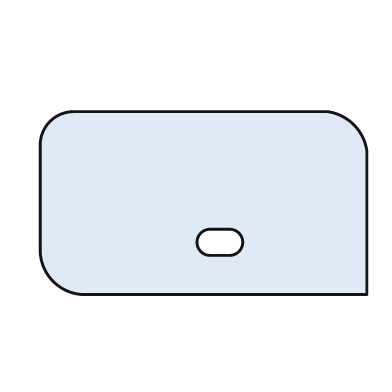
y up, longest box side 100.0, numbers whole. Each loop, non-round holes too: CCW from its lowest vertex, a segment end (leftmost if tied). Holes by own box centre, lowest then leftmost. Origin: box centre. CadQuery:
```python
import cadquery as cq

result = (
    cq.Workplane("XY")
    .moveTo(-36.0, -28.0)
    .lineTo(50.0, -28.0)
    .lineTo(50.0, 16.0)
    .threePointArc((46.0, 24.0), (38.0, 28.0))
    .lineTo(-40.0, 28.0)
    .threePointArc((-47.0, 25.0), (-50.0, 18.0))
    .lineTo(-50.0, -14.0)
    .threePointArc((-46.0, -24.0), (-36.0, -28.0))
    .close()
    .moveTo(2.0, -16.0)
    .lineTo(8.0, -16.0)
    .threePointArc((12.0, -12.0), (8.0, -8.0))
    .lineTo(2.0, -8.0)
    .threePointArc((-2.0, -12.0), (2.0, -16.0))
    .close()
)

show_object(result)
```